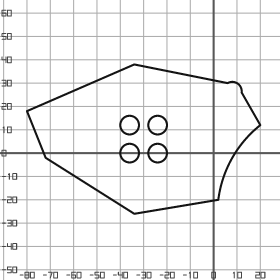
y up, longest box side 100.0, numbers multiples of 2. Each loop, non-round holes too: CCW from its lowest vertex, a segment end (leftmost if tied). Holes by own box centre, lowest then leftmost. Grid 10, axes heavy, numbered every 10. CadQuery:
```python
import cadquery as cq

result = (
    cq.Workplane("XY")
    .moveTo(-34.0, -26.0)
    .lineTo(2.0, -20.0)
    .threePointArc((8.0, -2.0), (20.0, 12.0))
    .lineTo(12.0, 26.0)
    .threePointArc((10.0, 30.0), (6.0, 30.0))
    .lineTo(-34.0, 38.0)
    .lineTo(-80.0, 18.0)
    .lineTo(-72.0, -2.0)
    .close()
    .moveTo(-36.0, 0.0)
    .circle(4.0)
    .moveTo(-24.0, 0.0)
    .circle(4.0)
    .moveTo(-36.0, 12.0)
    .circle(4.0)
    .moveTo(-24.0, 12.0)
    .circle(4.0)
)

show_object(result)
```